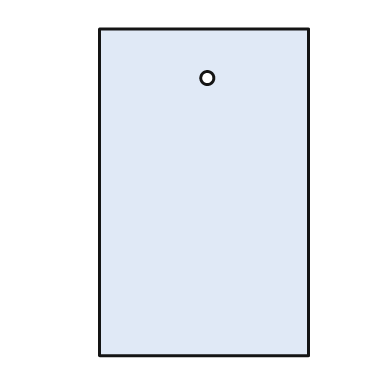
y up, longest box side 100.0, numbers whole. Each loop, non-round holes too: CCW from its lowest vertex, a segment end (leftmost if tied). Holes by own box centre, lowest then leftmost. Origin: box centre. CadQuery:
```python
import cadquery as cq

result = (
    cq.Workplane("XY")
    .moveTo(-32.0, -50.0)
    .lineTo(32.0, -50.0)
    .lineTo(32.0, 50.0)
    .lineTo(-32.0, 50.0)
    .close()
    .moveTo(1.0, 35.0)
    .circle(2.0)
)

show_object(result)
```